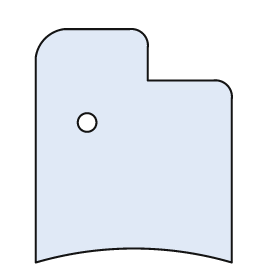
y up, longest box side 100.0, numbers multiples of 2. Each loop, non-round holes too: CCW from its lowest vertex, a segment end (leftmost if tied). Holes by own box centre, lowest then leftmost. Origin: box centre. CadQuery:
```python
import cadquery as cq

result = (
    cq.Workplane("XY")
    .moveTo(-42.0, -50.0)
    .threePointArc((0.0, -44.0), (42.0, -50.0))
    .lineTo(42.0, 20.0)
    .threePointArc((40.0, 26.0), (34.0, 28.0))
    .lineTo(6.0, 28.0)
    .lineTo(6.0, 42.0)
    .threePointArc((4.0, 48.0), (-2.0, 50.0))
    .lineTo(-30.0, 50.0)
    .threePointArc((-38.0, 46.0), (-42.0, 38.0))
    .close()
    .moveTo(-20.0, 10.0)
    .circle(4.0)
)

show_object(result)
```